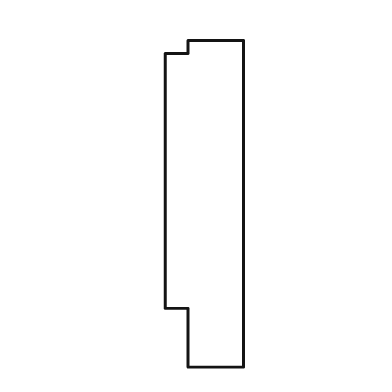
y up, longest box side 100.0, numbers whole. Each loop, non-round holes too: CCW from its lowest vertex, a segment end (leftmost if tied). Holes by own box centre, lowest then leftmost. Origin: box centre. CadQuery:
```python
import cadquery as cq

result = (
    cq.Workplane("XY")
    .moveTo(-5.0, -50.0)
    .lineTo(12.0, -50.0)
    .lineTo(12.0, 50.0)
    .lineTo(-5.0, 50.0)
    .lineTo(-5.0, 46.0)
    .lineTo(-12.0, 46.0)
    .lineTo(-12.0, -32.0)
    .lineTo(-5.0, -32.0)
    .close()
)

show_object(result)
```